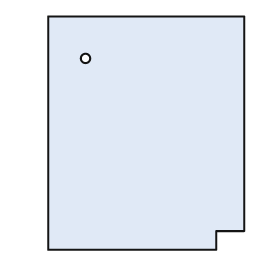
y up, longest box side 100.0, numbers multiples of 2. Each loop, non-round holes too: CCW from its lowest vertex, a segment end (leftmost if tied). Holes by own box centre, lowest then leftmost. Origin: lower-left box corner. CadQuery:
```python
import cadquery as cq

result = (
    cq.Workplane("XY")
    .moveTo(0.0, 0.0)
    .lineTo(72.0, 0.0)
    .lineTo(72.0, 8.0)
    .lineTo(84.0, 8.0)
    .lineTo(84.0, 100.0)
    .lineTo(0.0, 100.0)
    .close()
    .moveTo(16.0, 82.0)
    .circle(2.0)
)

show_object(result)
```